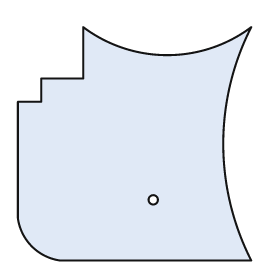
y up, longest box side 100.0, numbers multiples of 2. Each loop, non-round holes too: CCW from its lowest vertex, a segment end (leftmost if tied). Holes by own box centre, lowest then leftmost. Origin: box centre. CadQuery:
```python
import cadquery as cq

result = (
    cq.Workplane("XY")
    .moveTo(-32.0, -50.0)
    .lineTo(50.0, -50.0)
    .threePointArc((38.0, 0.0), (50.0, 50.0))
    .threePointArc((14.0, 38.0), (-22.0, 50.0))
    .lineTo(-22.0, 28.0)
    .lineTo(-40.0, 28.0)
    .lineTo(-40.0, 18.0)
    .lineTo(-50.0, 18.0)
    .lineTo(-50.0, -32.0)
    .threePointArc((-44.0, -44.0), (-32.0, -50.0))
    .close()
    .moveTo(8.0, -24.0)
    .circle(2.0)
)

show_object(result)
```